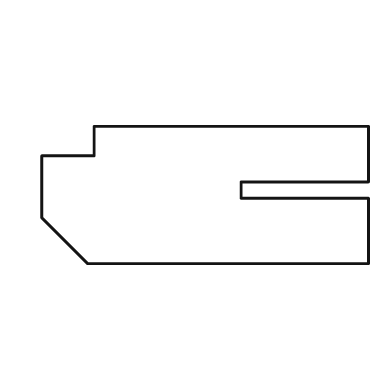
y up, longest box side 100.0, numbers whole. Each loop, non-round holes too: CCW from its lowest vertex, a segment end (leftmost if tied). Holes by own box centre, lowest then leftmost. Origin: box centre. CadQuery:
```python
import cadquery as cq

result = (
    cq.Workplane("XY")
    .moveTo(-36.0, -21.0)
    .lineTo(50.0, -21.0)
    .lineTo(50.0, -1.0)
    .lineTo(11.0, -1.0)
    .lineTo(11.0, 4.0)
    .lineTo(50.0, 4.0)
    .lineTo(50.0, 21.0)
    .lineTo(-34.0, 21.0)
    .lineTo(-34.0, 12.0)
    .lineTo(-50.0, 12.0)
    .lineTo(-50.0, -7.0)
    .close()
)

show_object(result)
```